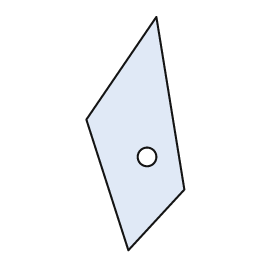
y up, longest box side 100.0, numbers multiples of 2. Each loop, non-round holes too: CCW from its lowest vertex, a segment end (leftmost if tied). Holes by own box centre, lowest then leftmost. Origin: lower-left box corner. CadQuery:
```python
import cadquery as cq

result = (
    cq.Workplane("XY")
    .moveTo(18.0, 0.0)
    .lineTo(42.0, 26.0)
    .lineTo(30.0, 100.0)
    .lineTo(0.0, 56.0)
    .close()
    .moveTo(26.0, 40.0)
    .circle(4.0)
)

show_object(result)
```